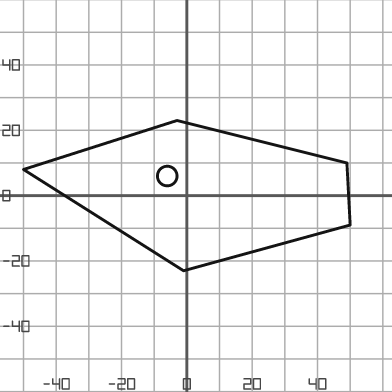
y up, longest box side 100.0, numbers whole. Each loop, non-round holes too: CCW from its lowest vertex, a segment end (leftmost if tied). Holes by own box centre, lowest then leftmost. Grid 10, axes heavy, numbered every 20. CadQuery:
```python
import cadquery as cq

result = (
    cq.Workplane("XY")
    .moveTo(-1.0, -23.0)
    .lineTo(50.0, -9.0)
    .lineTo(49.0, 10.0)
    .lineTo(-3.0, 23.0)
    .lineTo(-50.0, 8.0)
    .close()
    .moveTo(-6.0, 6.0)
    .circle(3.0)
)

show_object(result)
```